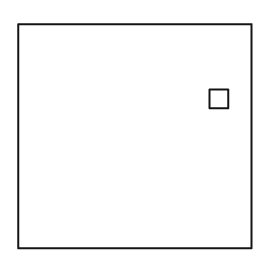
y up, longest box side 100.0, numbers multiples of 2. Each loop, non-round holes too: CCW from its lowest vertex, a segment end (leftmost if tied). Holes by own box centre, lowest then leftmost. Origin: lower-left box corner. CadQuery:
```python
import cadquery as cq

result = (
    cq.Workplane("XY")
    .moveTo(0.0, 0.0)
    .lineTo(100.0, 0.0)
    .lineTo(100.0, 96.0)
    .lineTo(0.0, 96.0)
    .close()
    .moveTo(82.0, 60.0)
    .lineTo(90.0, 60.0)
    .lineTo(90.0, 68.0)
    .lineTo(82.0, 68.0)
    .close()
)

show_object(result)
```